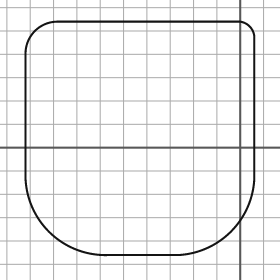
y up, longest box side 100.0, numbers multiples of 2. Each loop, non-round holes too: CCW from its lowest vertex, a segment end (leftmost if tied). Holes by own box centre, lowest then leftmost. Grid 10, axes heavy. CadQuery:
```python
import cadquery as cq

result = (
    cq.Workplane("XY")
    .moveTo(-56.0, -46.0)
    .lineTo(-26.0, -46.0)
    .threePointArc((-4.0, -36.0), (6.0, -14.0))
    .lineTo(6.0, 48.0)
    .threePointArc((4.0, 52.0), (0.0, 54.0))
    .lineTo(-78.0, 54.0)
    .threePointArc((-88.0, 50.0), (-92.0, 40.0))
    .lineTo(-92.0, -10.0)
    .threePointArc((-82.0, -36.0), (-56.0, -46.0))
    .close()
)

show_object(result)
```